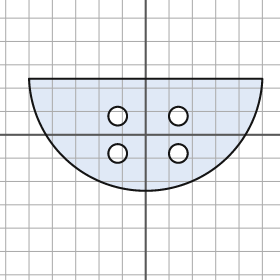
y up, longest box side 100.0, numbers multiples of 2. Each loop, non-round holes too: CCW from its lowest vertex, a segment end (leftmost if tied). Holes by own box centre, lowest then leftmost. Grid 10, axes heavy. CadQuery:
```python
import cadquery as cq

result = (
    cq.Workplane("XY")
    .moveTo(-50.0, 24.0)
    .threePointArc((0.0, -24.0), (50.0, 24.0))
    .close()
    .moveTo(-12.0, -8.0)
    .circle(4.0)
    .moveTo(14.0, -8.0)
    .circle(4.0)
    .moveTo(-12.0, 8.0)
    .circle(4.0)
    .moveTo(14.0, 8.0)
    .circle(4.0)
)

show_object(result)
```